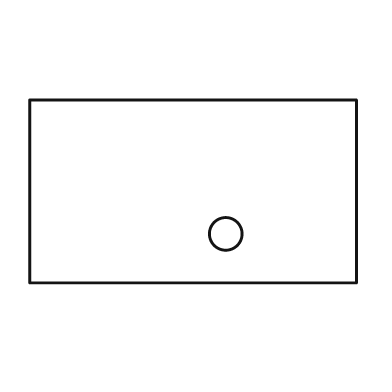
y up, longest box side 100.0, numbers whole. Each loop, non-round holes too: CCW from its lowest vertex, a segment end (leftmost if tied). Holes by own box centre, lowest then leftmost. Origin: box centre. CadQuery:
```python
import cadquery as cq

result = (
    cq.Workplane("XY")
    .moveTo(-50.0, -28.0)
    .lineTo(50.0, -28.0)
    .lineTo(50.0, 28.0)
    .lineTo(-50.0, 28.0)
    .close()
    .moveTo(10.0, -13.0)
    .circle(5.0)
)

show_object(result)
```